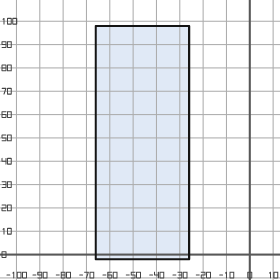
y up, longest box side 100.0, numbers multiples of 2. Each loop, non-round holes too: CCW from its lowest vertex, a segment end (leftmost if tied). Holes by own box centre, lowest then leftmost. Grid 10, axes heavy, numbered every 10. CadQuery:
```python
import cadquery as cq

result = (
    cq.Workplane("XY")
    .moveTo(-66.0, -2.0)
    .lineTo(-26.0, -2.0)
    .lineTo(-26.0, 98.0)
    .lineTo(-66.0, 98.0)
    .close()
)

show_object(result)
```